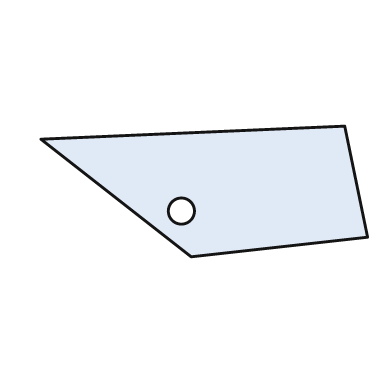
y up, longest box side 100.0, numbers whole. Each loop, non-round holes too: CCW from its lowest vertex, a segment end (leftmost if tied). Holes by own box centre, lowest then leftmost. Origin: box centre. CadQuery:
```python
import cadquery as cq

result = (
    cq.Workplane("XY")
    .moveTo(-4.0, -20.0)
    .lineTo(50.0, -14.0)
    .lineTo(43.0, 20.0)
    .lineTo(-50.0, 16.0)
    .close()
    .moveTo(-7.0, -6.0)
    .circle(4.0)
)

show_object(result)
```